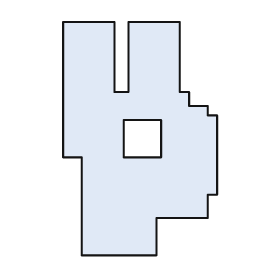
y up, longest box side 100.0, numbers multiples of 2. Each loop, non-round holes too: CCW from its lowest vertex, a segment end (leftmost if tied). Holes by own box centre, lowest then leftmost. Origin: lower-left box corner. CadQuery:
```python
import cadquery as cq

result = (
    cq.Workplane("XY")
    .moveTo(8.0, 0.0)
    .lineTo(40.0, 0.0)
    .lineTo(40.0, 16.0)
    .lineTo(62.0, 16.0)
    .lineTo(62.0, 26.0)
    .lineTo(66.0, 26.0)
    .lineTo(66.0, 60.0)
    .lineTo(62.0, 60.0)
    .lineTo(62.0, 64.0)
    .lineTo(54.0, 64.0)
    .lineTo(54.0, 70.0)
    .lineTo(50.0, 70.0)
    .lineTo(50.0, 100.0)
    .lineTo(28.0, 100.0)
    .lineTo(28.0, 70.0)
    .lineTo(22.0, 70.0)
    .lineTo(22.0, 100.0)
    .lineTo(0.0, 100.0)
    .lineTo(0.0, 42.0)
    .lineTo(8.0, 42.0)
    .close()
    .moveTo(26.0, 42.0)
    .lineTo(42.0, 42.0)
    .lineTo(42.0, 58.0)
    .lineTo(26.0, 58.0)
    .close()
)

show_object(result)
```